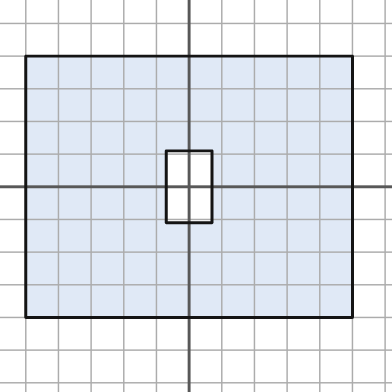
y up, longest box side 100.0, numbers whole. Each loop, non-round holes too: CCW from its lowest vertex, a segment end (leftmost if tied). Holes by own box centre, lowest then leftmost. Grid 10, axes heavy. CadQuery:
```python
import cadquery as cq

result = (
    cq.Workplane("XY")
    .moveTo(-50.0, -40.0)
    .lineTo(50.0, -40.0)
    .lineTo(50.0, 40.0)
    .lineTo(-50.0, 40.0)
    .close()
    .moveTo(-7.0, -11.0)
    .lineTo(7.0, -11.0)
    .lineTo(7.0, 11.0)
    .lineTo(-7.0, 11.0)
    .close()
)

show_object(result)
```